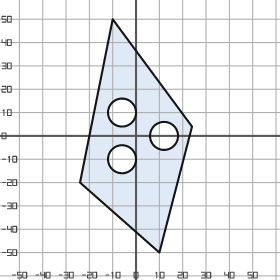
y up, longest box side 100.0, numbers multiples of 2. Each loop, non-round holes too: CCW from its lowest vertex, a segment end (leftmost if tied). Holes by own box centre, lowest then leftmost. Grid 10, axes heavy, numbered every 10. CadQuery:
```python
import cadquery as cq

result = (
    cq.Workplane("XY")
    .moveTo(10.0, -50.0)
    .lineTo(24.0, 4.0)
    .lineTo(-10.0, 50.0)
    .lineTo(-24.0, -20.0)
    .close()
    .moveTo(-6.0, -10.0)
    .circle(6.0)
    .moveTo(12.0, 0.0)
    .circle(6.0)
    .moveTo(-6.0, 10.0)
    .circle(6.0)
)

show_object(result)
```